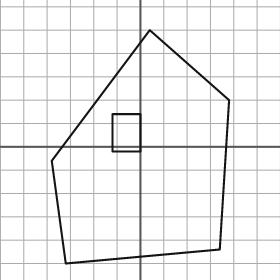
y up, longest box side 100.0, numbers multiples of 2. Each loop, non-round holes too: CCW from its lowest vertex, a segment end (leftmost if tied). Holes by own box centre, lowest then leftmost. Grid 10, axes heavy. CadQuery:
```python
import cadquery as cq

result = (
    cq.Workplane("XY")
    .moveTo(-32.0, -50.0)
    .lineTo(34.0, -44.0)
    .lineTo(38.0, 20.0)
    .lineTo(4.0, 50.0)
    .lineTo(-38.0, -6.0)
    .close()
    .moveTo(-12.0, -2.0)
    .lineTo(0.0, -2.0)
    .lineTo(0.0, 14.0)
    .lineTo(-12.0, 14.0)
    .close()
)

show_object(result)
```